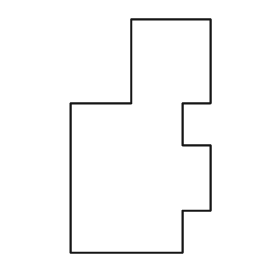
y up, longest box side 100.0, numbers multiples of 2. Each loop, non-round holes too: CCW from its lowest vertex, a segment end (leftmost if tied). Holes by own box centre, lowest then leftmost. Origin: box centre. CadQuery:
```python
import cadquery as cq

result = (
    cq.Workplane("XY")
    .moveTo(-30.0, -50.0)
    .lineTo(18.0, -50.0)
    .lineTo(18.0, -32.0)
    .lineTo(30.0, -32.0)
    .lineTo(30.0, -4.0)
    .lineTo(18.0, -4.0)
    .lineTo(18.0, 14.0)
    .lineTo(30.0, 14.0)
    .lineTo(30.0, 50.0)
    .lineTo(-4.0, 50.0)
    .lineTo(-4.0, 14.0)
    .lineTo(-30.0, 14.0)
    .close()
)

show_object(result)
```